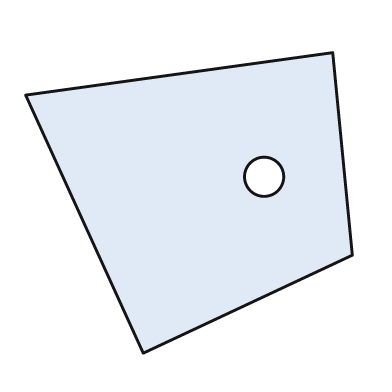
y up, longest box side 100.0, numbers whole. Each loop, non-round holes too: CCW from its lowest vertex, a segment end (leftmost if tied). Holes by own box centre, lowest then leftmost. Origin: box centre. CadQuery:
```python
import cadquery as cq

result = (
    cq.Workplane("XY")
    .moveTo(-14.0, -46.0)
    .lineTo(50.0, -16.0)
    .lineTo(44.0, 46.0)
    .lineTo(-50.0, 33.0)
    .close()
    .moveTo(23.0, 8.0)
    .circle(6.0)
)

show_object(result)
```